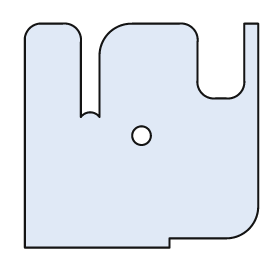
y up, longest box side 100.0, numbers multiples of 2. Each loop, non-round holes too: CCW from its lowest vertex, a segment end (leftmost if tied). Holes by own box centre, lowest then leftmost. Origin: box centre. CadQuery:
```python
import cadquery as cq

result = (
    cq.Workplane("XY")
    .moveTo(-50.0, -48.0)
    .lineTo(12.0, -48.0)
    .lineTo(12.0, -44.0)
    .lineTo(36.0, -44.0)
    .threePointArc((46.0, -40.0), (50.0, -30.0))
    .lineTo(50.0, 48.0)
    .lineTo(44.0, 48.0)
    .lineTo(44.0, 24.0)
    .threePointArc((42.0, 18.0), (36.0, 16.0))
    .lineTo(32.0, 16.0)
    .threePointArc((26.0, 18.0), (24.0, 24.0))
    .lineTo(24.0, 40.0)
    .threePointArc((22.0, 46.0), (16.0, 48.0))
    .lineTo(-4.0, 48.0)
    .threePointArc((-14.0, 44.0), (-18.0, 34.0))
    .lineTo(-18.0, 8.0)
    .threePointArc((-22.0, 10.0), (-26.0, 8.0))
    .lineTo(-26.0, 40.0)
    .threePointArc((-28.0, 46.0), (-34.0, 48.0))
    .lineTo(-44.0, 48.0)
    .threePointArc((-48.0, 46.0), (-50.0, 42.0))
    .close()
    .moveTo(0.0, 0.0)
    .circle(4.0)
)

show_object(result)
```